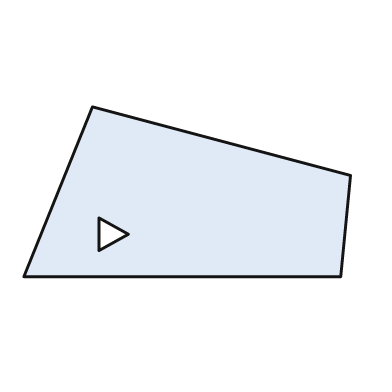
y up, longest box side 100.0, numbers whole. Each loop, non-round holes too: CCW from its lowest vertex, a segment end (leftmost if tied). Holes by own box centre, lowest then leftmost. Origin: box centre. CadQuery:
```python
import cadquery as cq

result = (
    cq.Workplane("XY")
    .moveTo(-50.0, -26.0)
    .lineTo(47.0, -26.0)
    .lineTo(50.0, 5.0)
    .lineTo(-29.0, 26.0)
    .close()
    .moveTo(-27.0, -18.0)
    .lineTo(-18.0, -13.0)
    .lineTo(-27.0, -8.0)
    .close()
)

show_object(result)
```